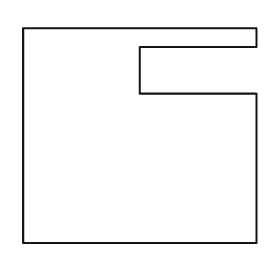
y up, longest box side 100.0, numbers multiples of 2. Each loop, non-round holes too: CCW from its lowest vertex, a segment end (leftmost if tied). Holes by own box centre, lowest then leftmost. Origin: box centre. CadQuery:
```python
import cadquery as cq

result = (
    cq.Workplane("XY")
    .moveTo(-50.0, -46.0)
    .lineTo(50.0, -46.0)
    .lineTo(50.0, 18.0)
    .lineTo(0.0, 18.0)
    .lineTo(0.0, 38.0)
    .lineTo(50.0, 38.0)
    .lineTo(50.0, 46.0)
    .lineTo(-50.0, 46.0)
    .close()
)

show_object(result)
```